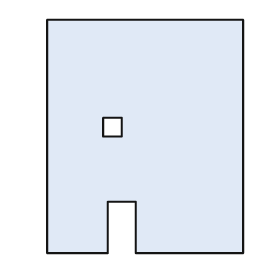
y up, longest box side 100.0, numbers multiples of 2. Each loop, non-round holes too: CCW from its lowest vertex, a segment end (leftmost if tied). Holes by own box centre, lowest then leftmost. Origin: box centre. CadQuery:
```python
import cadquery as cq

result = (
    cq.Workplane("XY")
    .moveTo(-42.0, -50.0)
    .lineTo(-16.0, -50.0)
    .lineTo(-16.0, -28.0)
    .lineTo(-4.0, -28.0)
    .lineTo(-4.0, -50.0)
    .lineTo(42.0, -50.0)
    .lineTo(42.0, 50.0)
    .lineTo(-42.0, 50.0)
    .close()
    .moveTo(-18.0, 0.0)
    .lineTo(-10.0, 0.0)
    .lineTo(-10.0, 8.0)
    .lineTo(-18.0, 8.0)
    .close()
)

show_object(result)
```